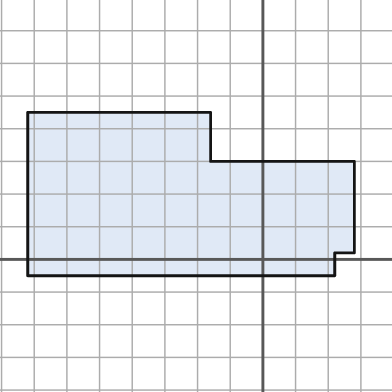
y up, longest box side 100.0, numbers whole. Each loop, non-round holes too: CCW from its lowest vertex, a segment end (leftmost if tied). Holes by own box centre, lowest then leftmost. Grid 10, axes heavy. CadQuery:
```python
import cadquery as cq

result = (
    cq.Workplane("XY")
    .moveTo(-72.0, -5.0)
    .lineTo(22.0, -5.0)
    .lineTo(22.0, 2.0)
    .lineTo(28.0, 2.0)
    .lineTo(28.0, 30.0)
    .lineTo(-16.0, 30.0)
    .lineTo(-16.0, 45.0)
    .lineTo(-72.0, 45.0)
    .close()
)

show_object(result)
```